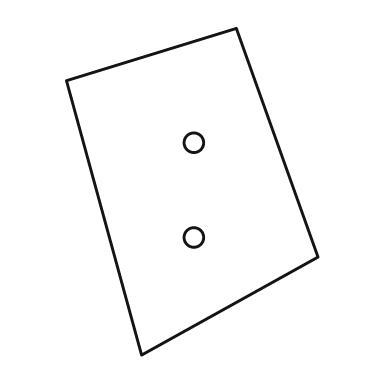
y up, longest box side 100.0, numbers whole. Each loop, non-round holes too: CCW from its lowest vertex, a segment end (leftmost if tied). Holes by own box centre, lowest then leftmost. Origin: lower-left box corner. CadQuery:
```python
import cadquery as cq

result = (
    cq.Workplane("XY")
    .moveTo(23.0, 0.0)
    .lineTo(77.0, 30.0)
    .lineTo(52.0, 100.0)
    .lineTo(0.0, 84.0)
    .close()
    .moveTo(39.0, 36.0)
    .circle(3.0)
    .moveTo(39.0, 65.0)
    .circle(3.0)
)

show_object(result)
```